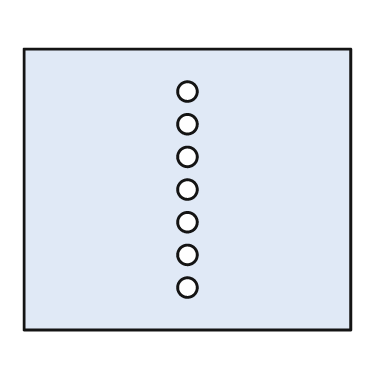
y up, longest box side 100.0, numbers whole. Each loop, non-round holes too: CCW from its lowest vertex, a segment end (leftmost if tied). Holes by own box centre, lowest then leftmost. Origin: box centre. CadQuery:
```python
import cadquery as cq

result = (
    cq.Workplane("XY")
    .moveTo(-50.0, -43.0)
    .lineTo(50.0, -43.0)
    .lineTo(50.0, 43.0)
    .lineTo(-50.0, 43.0)
    .close()
    .moveTo(0.0, -30.0)
    .circle(3.0)
    .moveTo(0.0, -20.0)
    .circle(3.0)
    .moveTo(0.0, -10.0)
    .circle(3.0)
    .moveTo(0.0, 0.0)
    .circle(3.0)
    .moveTo(0.0, 10.0)
    .circle(3.0)
    .moveTo(0.0, 20.0)
    .circle(3.0)
    .moveTo(0.0, 30.0)
    .circle(3.0)
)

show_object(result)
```